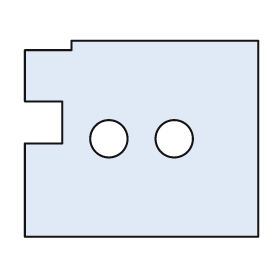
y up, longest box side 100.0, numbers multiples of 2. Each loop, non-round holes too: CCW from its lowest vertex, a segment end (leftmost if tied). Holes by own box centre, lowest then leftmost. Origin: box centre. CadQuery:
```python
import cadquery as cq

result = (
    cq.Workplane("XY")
    .moveTo(-50.0, -42.0)
    .lineTo(50.0, -42.0)
    .lineTo(50.0, 42.0)
    .lineTo(-30.0, 42.0)
    .lineTo(-30.0, 38.0)
    .lineTo(-50.0, 38.0)
    .lineTo(-50.0, 16.0)
    .lineTo(-34.0, 16.0)
    .lineTo(-34.0, -2.0)
    .lineTo(-50.0, -2.0)
    .close()
    .moveTo(-14.0, 0.0)
    .circle(8.0)
    .moveTo(14.0, 0.0)
    .circle(8.0)
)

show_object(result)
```